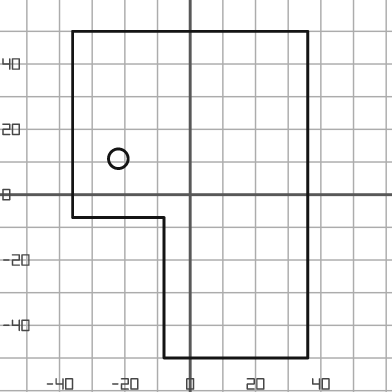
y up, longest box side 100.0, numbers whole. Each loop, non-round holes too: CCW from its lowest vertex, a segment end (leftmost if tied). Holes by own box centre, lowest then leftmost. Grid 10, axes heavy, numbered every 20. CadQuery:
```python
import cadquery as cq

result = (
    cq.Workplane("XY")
    .moveTo(-8.0, -50.0)
    .lineTo(36.0, -50.0)
    .lineTo(36.0, 50.0)
    .lineTo(-36.0, 50.0)
    .lineTo(-36.0, -7.0)
    .lineTo(-8.0, -7.0)
    .close()
    .moveTo(-22.0, 11.0)
    .circle(3.0)
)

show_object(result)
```